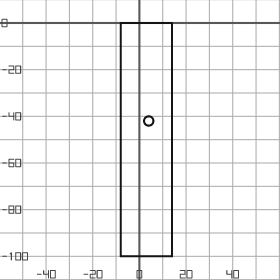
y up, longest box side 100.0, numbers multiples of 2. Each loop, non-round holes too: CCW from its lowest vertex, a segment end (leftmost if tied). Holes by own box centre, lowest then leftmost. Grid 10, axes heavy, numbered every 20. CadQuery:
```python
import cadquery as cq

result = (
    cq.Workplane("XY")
    .moveTo(-8.0, -100.0)
    .lineTo(14.0, -100.0)
    .lineTo(14.0, 0.0)
    .lineTo(-8.0, 0.0)
    .close()
    .moveTo(4.0, -42.0)
    .circle(2.0)
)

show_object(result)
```